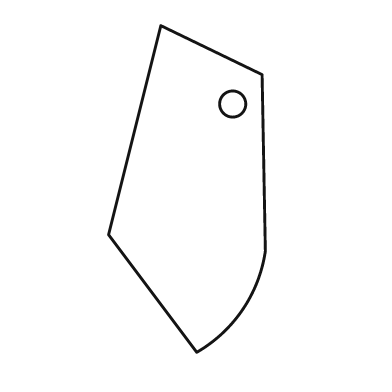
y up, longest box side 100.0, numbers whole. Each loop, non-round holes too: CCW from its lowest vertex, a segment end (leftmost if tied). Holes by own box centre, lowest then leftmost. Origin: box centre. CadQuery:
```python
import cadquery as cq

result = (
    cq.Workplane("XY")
    .moveTo(3.0, -50.0)
    .threePointArc((17.0, -37.0), (24.0, -19.0))
    .lineTo(23.0, 35.0)
    .lineTo(-8.0, 50.0)
    .lineTo(-24.0, -14.0)
    .close()
    .moveTo(14.0, 26.0)
    .circle(4.0)
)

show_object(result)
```